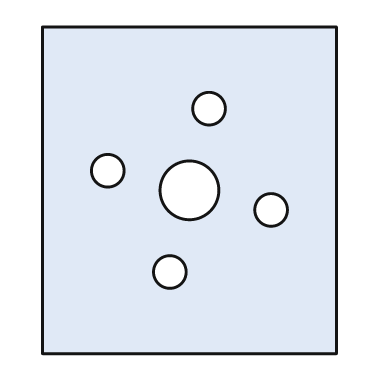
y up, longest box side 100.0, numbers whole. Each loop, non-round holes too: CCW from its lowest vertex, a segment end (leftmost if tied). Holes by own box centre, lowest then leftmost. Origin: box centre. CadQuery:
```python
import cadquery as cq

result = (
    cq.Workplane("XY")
    .moveTo(-45.0, -50.0)
    .lineTo(45.0, -50.0)
    .lineTo(45.0, 50.0)
    .lineTo(-45.0, 50.0)
    .close()
    .moveTo(-6.0, -25.0)
    .circle(5.0)
    .moveTo(25.0, -6.0)
    .circle(5.0)
    .moveTo(0.0, 0.0)
    .circle(9.0)
    .moveTo(-25.0, 6.0)
    .circle(5.0)
    .moveTo(6.0, 25.0)
    .circle(5.0)
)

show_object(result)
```